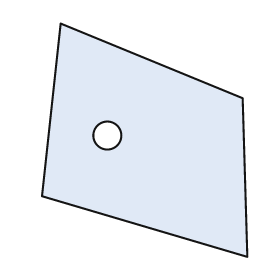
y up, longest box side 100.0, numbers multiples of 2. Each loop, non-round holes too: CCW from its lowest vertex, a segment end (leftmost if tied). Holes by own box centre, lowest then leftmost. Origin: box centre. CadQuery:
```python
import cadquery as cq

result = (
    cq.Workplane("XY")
    .moveTo(44.0, -50.0)
    .lineTo(42.0, 18.0)
    .lineTo(-36.0, 50.0)
    .lineTo(-44.0, -24.0)
    .close()
    .moveTo(-16.0, 2.0)
    .circle(6.0)
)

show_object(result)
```